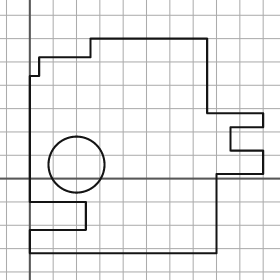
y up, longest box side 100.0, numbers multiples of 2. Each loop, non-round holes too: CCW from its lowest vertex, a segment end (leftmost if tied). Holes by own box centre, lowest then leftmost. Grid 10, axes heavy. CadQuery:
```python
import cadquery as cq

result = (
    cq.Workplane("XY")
    .moveTo(0.0, -32.0)
    .lineTo(80.0, -32.0)
    .lineTo(80.0, 2.0)
    .lineTo(100.0, 2.0)
    .lineTo(100.0, 12.0)
    .lineTo(86.0, 12.0)
    .lineTo(86.0, 22.0)
    .lineTo(100.0, 22.0)
    .lineTo(100.0, 28.0)
    .lineTo(76.0, 28.0)
    .lineTo(76.0, 60.0)
    .lineTo(26.0, 60.0)
    .lineTo(26.0, 52.0)
    .lineTo(4.0, 52.0)
    .lineTo(4.0, 44.0)
    .lineTo(0.0, 44.0)
    .lineTo(0.0, -10.0)
    .lineTo(24.0, -10.0)
    .lineTo(24.0, -22.0)
    .lineTo(0.0, -22.0)
    .close()
    .moveTo(20.0, 6.0)
    .circle(12.0)
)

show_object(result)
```